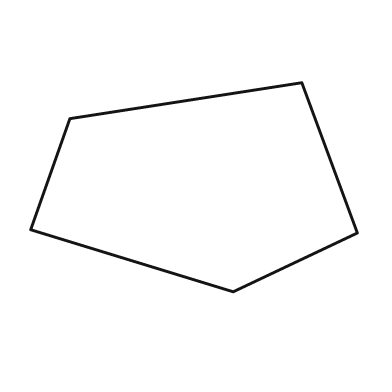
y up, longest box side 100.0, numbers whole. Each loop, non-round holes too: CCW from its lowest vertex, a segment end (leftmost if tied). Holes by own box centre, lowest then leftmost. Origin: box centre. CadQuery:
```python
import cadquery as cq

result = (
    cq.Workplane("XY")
    .moveTo(12.0, -32.0)
    .lineTo(50.0, -14.0)
    .lineTo(33.0, 32.0)
    .lineTo(-38.0, 21.0)
    .lineTo(-50.0, -13.0)
    .close()
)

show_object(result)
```